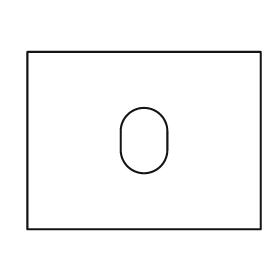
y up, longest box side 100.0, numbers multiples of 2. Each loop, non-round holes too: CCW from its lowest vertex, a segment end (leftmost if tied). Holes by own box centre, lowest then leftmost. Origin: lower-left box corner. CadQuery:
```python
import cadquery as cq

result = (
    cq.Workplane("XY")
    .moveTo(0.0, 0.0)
    .lineTo(100.0, 0.0)
    .lineTo(100.0, 76.0)
    .lineTo(0.0, 76.0)
    .close()
    .moveTo(40.0, 34.0)
    .threePointArc((50.0, 24.0), (60.0, 34.0))
    .lineTo(60.0, 42.0)
    .threePointArc((50.0, 52.0), (40.0, 42.0))
    .close()
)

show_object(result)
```